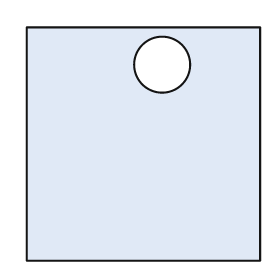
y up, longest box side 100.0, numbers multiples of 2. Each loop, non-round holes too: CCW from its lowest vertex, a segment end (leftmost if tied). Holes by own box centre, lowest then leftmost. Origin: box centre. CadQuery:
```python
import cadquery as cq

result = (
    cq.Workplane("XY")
    .moveTo(-50.0, -50.0)
    .lineTo(50.0, -50.0)
    .lineTo(50.0, 50.0)
    .lineTo(-50.0, 50.0)
    .close()
    .moveTo(8.0, 34.0)
    .circle(12.0)
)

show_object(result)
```